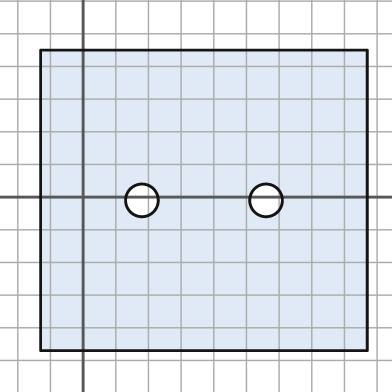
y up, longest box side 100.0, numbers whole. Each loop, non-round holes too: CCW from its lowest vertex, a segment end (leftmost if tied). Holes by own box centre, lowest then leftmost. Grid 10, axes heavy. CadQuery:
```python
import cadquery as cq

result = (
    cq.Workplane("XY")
    .moveTo(-13.0, -47.0)
    .lineTo(87.0, -47.0)
    .lineTo(87.0, 45.0)
    .lineTo(-13.0, 45.0)
    .close()
    .moveTo(18.0, -1.0)
    .circle(5.0)
    .moveTo(56.0, -1.0)
    .circle(5.0)
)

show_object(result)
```